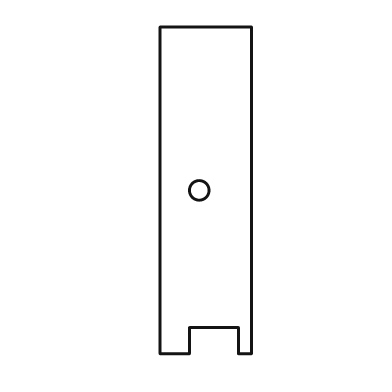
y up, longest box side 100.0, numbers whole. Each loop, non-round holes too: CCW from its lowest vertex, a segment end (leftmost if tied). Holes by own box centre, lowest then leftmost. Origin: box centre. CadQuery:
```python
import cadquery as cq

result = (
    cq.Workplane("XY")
    .moveTo(-14.0, -50.0)
    .lineTo(-5.0, -50.0)
    .lineTo(-5.0, -42.0)
    .lineTo(10.0, -42.0)
    .lineTo(10.0, -50.0)
    .lineTo(14.0, -50.0)
    .lineTo(14.0, 50.0)
    .lineTo(-14.0, 50.0)
    .close()
    .moveTo(-2.0, 0.0)
    .circle(3.0)
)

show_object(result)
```